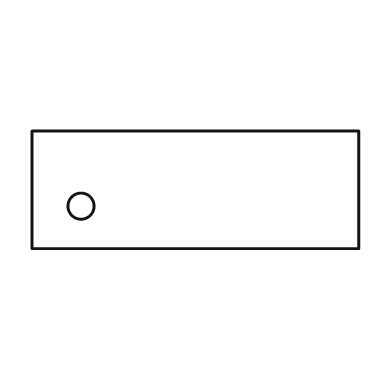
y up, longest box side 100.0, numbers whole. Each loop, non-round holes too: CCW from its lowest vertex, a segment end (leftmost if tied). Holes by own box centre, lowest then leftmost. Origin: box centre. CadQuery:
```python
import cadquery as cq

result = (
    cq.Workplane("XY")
    .moveTo(-50.0, -18.0)
    .lineTo(50.0, -18.0)
    .lineTo(50.0, 18.0)
    .lineTo(-50.0, 18.0)
    .close()
    .moveTo(-35.0, -5.0)
    .circle(4.0)
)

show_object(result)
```